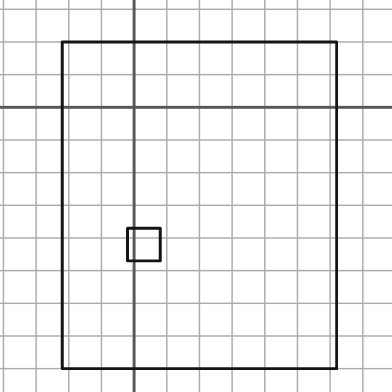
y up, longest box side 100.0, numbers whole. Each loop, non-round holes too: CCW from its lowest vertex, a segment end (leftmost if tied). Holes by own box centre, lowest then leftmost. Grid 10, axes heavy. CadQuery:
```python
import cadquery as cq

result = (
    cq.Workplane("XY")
    .moveTo(-22.0, -80.0)
    .lineTo(62.0, -80.0)
    .lineTo(62.0, 20.0)
    .lineTo(-22.0, 20.0)
    .close()
    .moveTo(-2.0, -47.0)
    .lineTo(8.0, -47.0)
    .lineTo(8.0, -37.0)
    .lineTo(-2.0, -37.0)
    .close()
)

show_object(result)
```